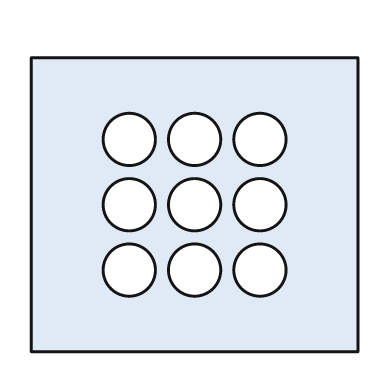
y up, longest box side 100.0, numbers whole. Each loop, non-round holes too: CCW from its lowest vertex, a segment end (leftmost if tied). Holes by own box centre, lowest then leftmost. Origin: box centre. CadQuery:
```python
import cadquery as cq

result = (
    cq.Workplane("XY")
    .moveTo(-50.0, -45.0)
    .lineTo(50.0, -45.0)
    .lineTo(50.0, 45.0)
    .lineTo(-50.0, 45.0)
    .close()
    .moveTo(-20.0, -20.0)
    .circle(8.0)
    .moveTo(0.0, -20.0)
    .circle(8.0)
    .moveTo(20.0, -20.0)
    .circle(8.0)
    .moveTo(-20.0, 0.0)
    .circle(8.0)
    .moveTo(0.0, 0.0)
    .circle(8.0)
    .moveTo(20.0, 0.0)
    .circle(8.0)
    .moveTo(-20.0, 20.0)
    .circle(8.0)
    .moveTo(0.0, 20.0)
    .circle(8.0)
    .moveTo(20.0, 20.0)
    .circle(8.0)
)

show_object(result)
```